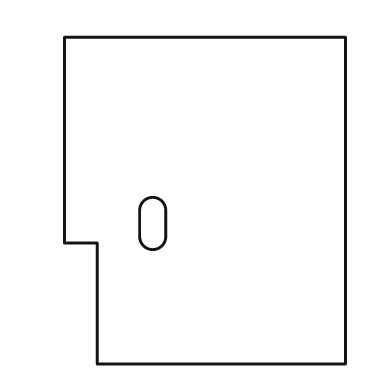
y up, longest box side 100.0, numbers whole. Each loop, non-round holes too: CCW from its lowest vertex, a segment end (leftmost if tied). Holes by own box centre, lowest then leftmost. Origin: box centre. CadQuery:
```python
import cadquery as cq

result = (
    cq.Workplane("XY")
    .moveTo(-33.0, -50.0)
    .lineTo(43.0, -50.0)
    .lineTo(43.0, 50.0)
    .lineTo(-43.0, 50.0)
    .lineTo(-43.0, -13.0)
    .lineTo(-33.0, -13.0)
    .close()
    .moveTo(-20.0, -11.0)
    .threePointArc((-16.0, -15.0), (-12.0, -11.0))
    .lineTo(-12.0, -3.0)
    .threePointArc((-16.0, 1.0), (-20.0, -3.0))
    .close()
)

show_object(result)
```